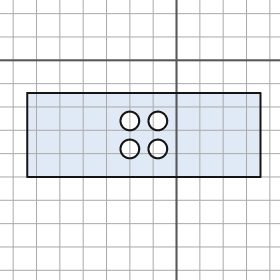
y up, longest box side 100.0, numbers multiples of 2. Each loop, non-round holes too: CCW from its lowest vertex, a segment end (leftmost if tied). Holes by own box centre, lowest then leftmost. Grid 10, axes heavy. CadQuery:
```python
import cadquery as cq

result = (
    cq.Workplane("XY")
    .moveTo(-64.0, -50.0)
    .lineTo(36.0, -50.0)
    .lineTo(36.0, -14.0)
    .lineTo(-64.0, -14.0)
    .close()
    .moveTo(-20.0, -38.0)
    .circle(4.0)
    .moveTo(-8.0, -38.0)
    .circle(4.0)
    .moveTo(-20.0, -26.0)
    .circle(4.0)
    .moveTo(-8.0, -26.0)
    .circle(4.0)
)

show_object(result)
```